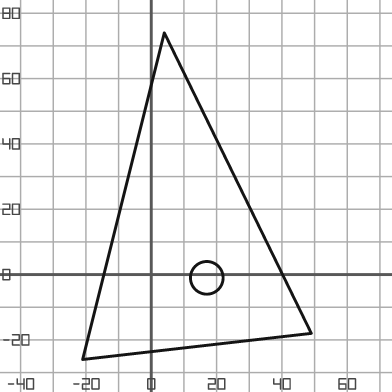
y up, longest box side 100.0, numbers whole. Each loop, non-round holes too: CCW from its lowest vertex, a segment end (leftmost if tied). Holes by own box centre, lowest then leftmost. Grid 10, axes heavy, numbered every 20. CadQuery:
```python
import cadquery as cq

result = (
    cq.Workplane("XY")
    .moveTo(-21.0, -26.0)
    .lineTo(49.0, -18.0)
    .lineTo(4.0, 74.0)
    .close()
    .moveTo(17.0, -1.0)
    .circle(5.0)
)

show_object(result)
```